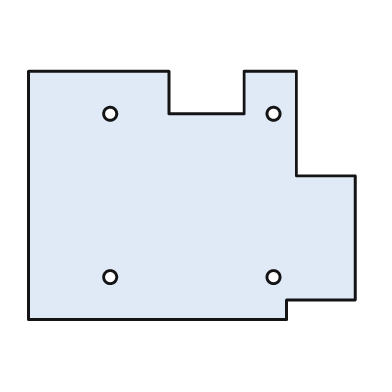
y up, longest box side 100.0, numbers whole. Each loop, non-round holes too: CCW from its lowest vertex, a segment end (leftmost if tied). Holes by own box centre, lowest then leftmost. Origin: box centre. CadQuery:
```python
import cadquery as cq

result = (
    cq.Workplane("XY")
    .moveTo(-50.0, -38.0)
    .lineTo(29.0, -38.0)
    .lineTo(29.0, -32.0)
    .lineTo(50.0, -32.0)
    .lineTo(50.0, 6.0)
    .lineTo(32.0, 6.0)
    .lineTo(32.0, 38.0)
    .lineTo(16.0, 38.0)
    .lineTo(16.0, 25.0)
    .lineTo(-7.0, 25.0)
    .lineTo(-7.0, 38.0)
    .lineTo(-50.0, 38.0)
    .close()
    .moveTo(-25.0, -25.0)
    .circle(2.0)
    .moveTo(25.0, -25.0)
    .circle(2.0)
    .moveTo(-25.0, 25.0)
    .circle(2.0)
    .moveTo(25.0, 25.0)
    .circle(2.0)
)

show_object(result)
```